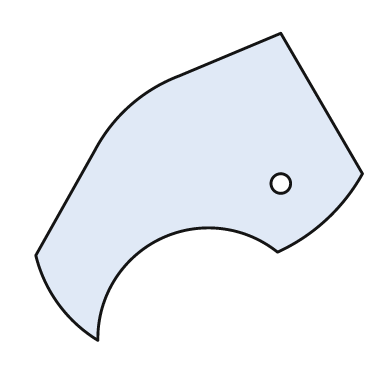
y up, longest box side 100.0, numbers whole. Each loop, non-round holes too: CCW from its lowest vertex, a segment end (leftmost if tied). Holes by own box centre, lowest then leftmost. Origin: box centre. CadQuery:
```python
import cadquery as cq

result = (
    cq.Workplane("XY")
    .moveTo(-31.0, -47.0)
    .threePointArc((-12.0, -16.0), (24.0, -20.0))
    .threePointArc((39.0, -10.0), (50.0, 4.0))
    .lineTo(25.0, 47.0)
    .lineTo(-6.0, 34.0)
    .threePointArc((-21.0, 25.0), (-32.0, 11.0))
    .lineTo(-50.0, -21.0)
    .threePointArc((-43.0, -36.0), (-31.0, -47.0))
    .close()
    .moveTo(25.0, 1.0)
    .circle(3.0)
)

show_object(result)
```